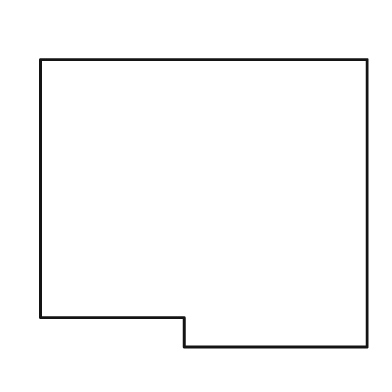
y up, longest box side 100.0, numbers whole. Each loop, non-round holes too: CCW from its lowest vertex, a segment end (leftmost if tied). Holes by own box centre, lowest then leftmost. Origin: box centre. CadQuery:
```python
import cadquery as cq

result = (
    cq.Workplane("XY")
    .moveTo(-6.0, -44.0)
    .lineTo(50.0, -44.0)
    .lineTo(50.0, 44.0)
    .lineTo(-50.0, 44.0)
    .lineTo(-50.0, -35.0)
    .lineTo(-6.0, -35.0)
    .close()
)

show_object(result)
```